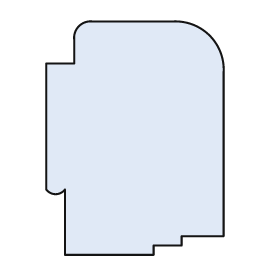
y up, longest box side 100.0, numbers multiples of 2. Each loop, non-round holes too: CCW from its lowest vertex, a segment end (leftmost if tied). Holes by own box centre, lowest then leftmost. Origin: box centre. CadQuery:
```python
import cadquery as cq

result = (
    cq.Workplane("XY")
    .moveTo(-30.0, -50.0)
    .lineTo(8.0, -50.0)
    .lineTo(8.0, -46.0)
    .lineTo(20.0, -46.0)
    .lineTo(20.0, -42.0)
    .lineTo(38.0, -42.0)
    .lineTo(38.0, 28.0)
    .threePointArc((32.0, 44.0), (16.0, 50.0))
    .lineTo(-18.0, 50.0)
    .threePointArc((-24.0, 48.0), (-26.0, 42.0))
    .lineTo(-26.0, 32.0)
    .lineTo(-38.0, 32.0)
    .lineTo(-38.0, -22.0)
    .threePointArc((-34.0, -24.0), (-30.0, -22.0))
    .close()
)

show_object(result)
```